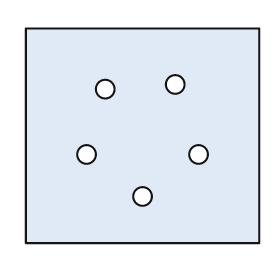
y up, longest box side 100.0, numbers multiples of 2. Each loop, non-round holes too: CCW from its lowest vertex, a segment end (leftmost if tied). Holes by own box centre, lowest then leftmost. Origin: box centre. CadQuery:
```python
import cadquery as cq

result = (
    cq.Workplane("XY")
    .moveTo(-50.0, -46.0)
    .lineTo(50.0, -46.0)
    .lineTo(50.0, 46.0)
    .lineTo(-50.0, 46.0)
    .close()
    .moveTo(0.0, -26.0)
    .circle(4.0)
    .moveTo(-24.0, -8.0)
    .circle(4.0)
    .moveTo(24.0, -8.0)
    .circle(4.0)
    .moveTo(-16.0, 20.0)
    .circle(4.0)
    .moveTo(14.0, 22.0)
    .circle(4.0)
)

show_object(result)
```